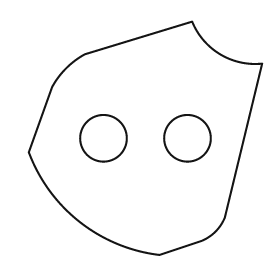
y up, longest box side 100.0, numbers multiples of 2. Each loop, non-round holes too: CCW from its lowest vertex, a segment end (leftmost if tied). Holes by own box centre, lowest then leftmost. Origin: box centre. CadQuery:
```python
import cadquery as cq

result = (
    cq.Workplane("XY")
    .moveTo(6.0, -50.0)
    .lineTo(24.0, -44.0)
    .threePointArc((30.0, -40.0), (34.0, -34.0))
    .lineTo(50.0, 32.0)
    .threePointArc((32.0, 36.0), (20.0, 50.0))
    .lineTo(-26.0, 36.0)
    .threePointArc((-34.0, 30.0), (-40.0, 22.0))
    .lineTo(-50.0, -6.0)
    .threePointArc((-28.0, -36.0), (6.0, -50.0))
    .close()
    .moveTo(-18.0, 0.0)
    .circle(10.0)
    .moveTo(18.0, 0.0)
    .circle(10.0)
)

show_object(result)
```